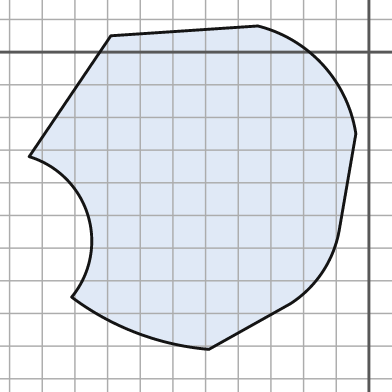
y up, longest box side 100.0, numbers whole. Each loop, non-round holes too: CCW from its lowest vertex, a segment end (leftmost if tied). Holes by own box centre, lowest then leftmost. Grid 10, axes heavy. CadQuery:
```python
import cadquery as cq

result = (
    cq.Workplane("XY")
    .moveTo(-49.0, -91.0)
    .lineTo(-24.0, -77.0)
    .threePointArc((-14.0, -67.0), (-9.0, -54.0))
    .lineTo(-4.0, -25.0)
    .threePointArc((-14.0, -4.0), (-34.0, 8.0))
    .lineTo(-79.0, 5.0)
    .lineTo(-104.0, -32.0)
    .threePointArc((-86.0, -50.0), (-91.0, -75.0))
    .threePointArc((-71.0, -86.0), (-49.0, -91.0))
    .close()
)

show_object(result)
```